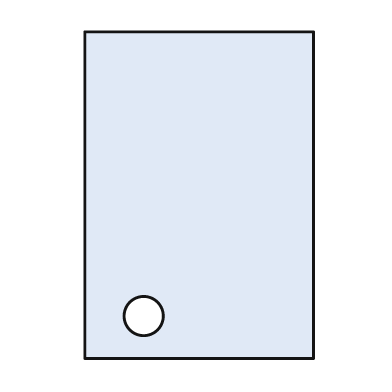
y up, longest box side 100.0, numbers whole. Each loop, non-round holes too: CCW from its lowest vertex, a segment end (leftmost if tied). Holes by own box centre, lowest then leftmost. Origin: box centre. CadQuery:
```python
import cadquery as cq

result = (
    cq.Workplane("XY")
    .moveTo(-35.0, -50.0)
    .lineTo(35.0, -50.0)
    .lineTo(35.0, 50.0)
    .lineTo(-35.0, 50.0)
    .close()
    .moveTo(-17.0, -37.0)
    .circle(6.0)
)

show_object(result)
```